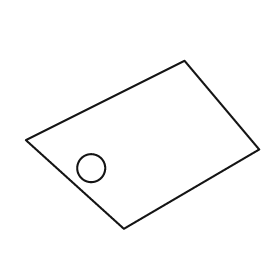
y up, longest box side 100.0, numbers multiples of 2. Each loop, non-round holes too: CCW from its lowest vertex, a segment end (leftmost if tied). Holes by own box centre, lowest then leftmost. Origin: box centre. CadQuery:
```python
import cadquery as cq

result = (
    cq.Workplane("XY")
    .moveTo(-8.0, -36.0)
    .lineTo(50.0, -2.0)
    .lineTo(18.0, 36.0)
    .lineTo(-50.0, 2.0)
    .close()
    .moveTo(-22.0, -10.0)
    .circle(6.0)
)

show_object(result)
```